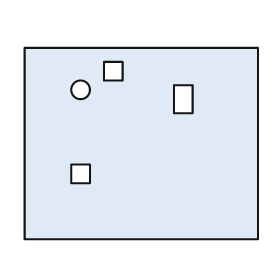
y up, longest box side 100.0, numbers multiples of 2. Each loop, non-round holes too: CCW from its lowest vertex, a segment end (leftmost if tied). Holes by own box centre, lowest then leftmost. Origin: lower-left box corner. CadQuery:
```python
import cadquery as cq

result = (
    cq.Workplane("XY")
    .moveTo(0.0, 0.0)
    .lineTo(100.0, 0.0)
    .lineTo(100.0, 82.0)
    .lineTo(0.0, 82.0)
    .close()
    .moveTo(20.0, 24.0)
    .lineTo(28.0, 24.0)
    .lineTo(28.0, 32.0)
    .lineTo(20.0, 32.0)
    .close()
    .moveTo(64.0, 54.0)
    .lineTo(72.0, 54.0)
    .lineTo(72.0, 66.0)
    .lineTo(64.0, 66.0)
    .close()
    .moveTo(24.0, 64.0)
    .circle(4.0)
    .moveTo(34.0, 68.0)
    .lineTo(42.0, 68.0)
    .lineTo(42.0, 76.0)
    .lineTo(34.0, 76.0)
    .close()
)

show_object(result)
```